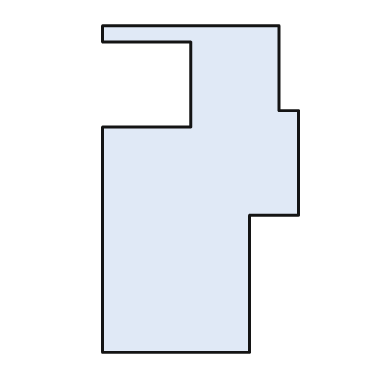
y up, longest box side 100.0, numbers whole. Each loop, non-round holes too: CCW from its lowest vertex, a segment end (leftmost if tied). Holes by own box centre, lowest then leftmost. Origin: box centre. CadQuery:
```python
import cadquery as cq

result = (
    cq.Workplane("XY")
    .moveTo(-30.0, -50.0)
    .lineTo(15.0, -50.0)
    .lineTo(15.0, -8.0)
    .lineTo(30.0, -8.0)
    .lineTo(30.0, 24.0)
    .lineTo(24.0, 24.0)
    .lineTo(24.0, 50.0)
    .lineTo(-30.0, 50.0)
    .lineTo(-30.0, 45.0)
    .lineTo(-3.0, 45.0)
    .lineTo(-3.0, 19.0)
    .lineTo(-30.0, 19.0)
    .close()
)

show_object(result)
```